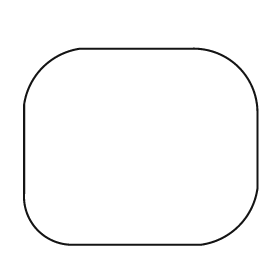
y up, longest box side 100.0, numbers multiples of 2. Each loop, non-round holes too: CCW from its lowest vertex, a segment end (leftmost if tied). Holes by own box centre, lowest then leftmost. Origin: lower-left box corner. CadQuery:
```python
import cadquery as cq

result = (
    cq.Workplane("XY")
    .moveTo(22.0, 0.0)
    .lineTo(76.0, 0.0)
    .threePointArc((92.0, 8.0), (100.0, 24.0))
    .lineTo(100.0, 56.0)
    .threePointArc((92.0, 76.0), (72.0, 84.0))
    .lineTo(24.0, 84.0)
    .threePointArc((8.0, 76.0), (0.0, 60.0))
    .lineTo(0.0, 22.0)
    .threePointArc((6.0, 6.0), (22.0, 0.0))
    .close()
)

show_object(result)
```